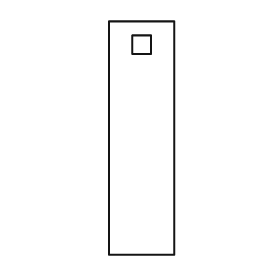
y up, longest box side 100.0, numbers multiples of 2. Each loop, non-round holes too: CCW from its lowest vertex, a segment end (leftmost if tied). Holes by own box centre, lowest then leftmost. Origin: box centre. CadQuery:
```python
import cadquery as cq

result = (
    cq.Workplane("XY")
    .moveTo(-14.0, -50.0)
    .lineTo(14.0, -50.0)
    .lineTo(14.0, 50.0)
    .lineTo(-14.0, 50.0)
    .close()
    .moveTo(-4.0, 36.0)
    .lineTo(4.0, 36.0)
    .lineTo(4.0, 44.0)
    .lineTo(-4.0, 44.0)
    .close()
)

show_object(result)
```